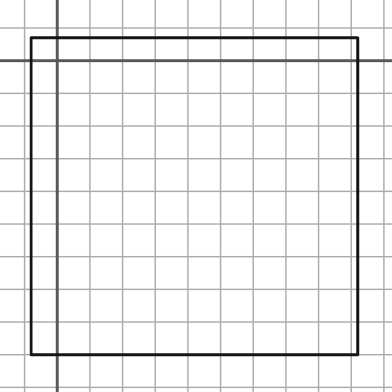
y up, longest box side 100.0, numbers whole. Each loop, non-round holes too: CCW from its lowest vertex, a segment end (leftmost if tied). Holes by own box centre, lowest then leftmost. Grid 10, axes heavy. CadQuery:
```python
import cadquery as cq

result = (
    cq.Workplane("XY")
    .moveTo(-8.0, -90.0)
    .lineTo(92.0, -90.0)
    .lineTo(92.0, 7.0)
    .lineTo(-8.0, 7.0)
    .close()
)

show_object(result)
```